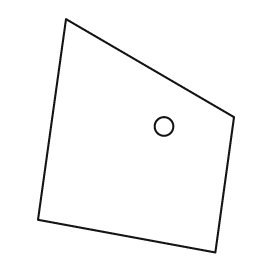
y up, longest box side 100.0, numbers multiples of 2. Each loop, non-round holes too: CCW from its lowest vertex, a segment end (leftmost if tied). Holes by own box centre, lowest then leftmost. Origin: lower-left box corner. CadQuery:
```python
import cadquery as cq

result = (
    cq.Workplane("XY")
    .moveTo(76.0, 0.0)
    .lineTo(84.0, 58.0)
    .lineTo(12.0, 100.0)
    .lineTo(0.0, 14.0)
    .close()
    .moveTo(54.0, 54.0)
    .circle(4.0)
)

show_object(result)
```